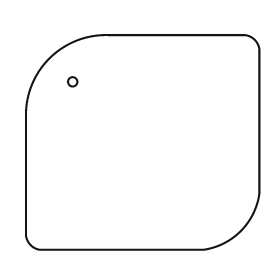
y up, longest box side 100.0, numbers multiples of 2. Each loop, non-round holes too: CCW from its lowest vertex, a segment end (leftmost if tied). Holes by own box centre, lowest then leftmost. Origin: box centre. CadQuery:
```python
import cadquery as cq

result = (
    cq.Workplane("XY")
    .moveTo(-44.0, -46.0)
    .lineTo(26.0, -46.0)
    .threePointArc((42.0, -38.0), (50.0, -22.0))
    .lineTo(50.0, 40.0)
    .threePointArc((48.0, 44.0), (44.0, 46.0))
    .lineTo(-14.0, 46.0)
    .threePointArc((-40.0, 36.0), (-50.0, 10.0))
    .lineTo(-50.0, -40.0)
    .threePointArc((-48.0, -44.0), (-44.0, -46.0))
    .close()
    .moveTo(-30.0, 26.0)
    .circle(2.0)
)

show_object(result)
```